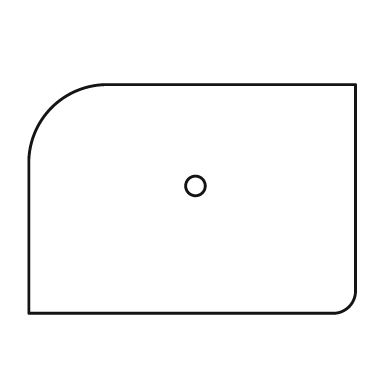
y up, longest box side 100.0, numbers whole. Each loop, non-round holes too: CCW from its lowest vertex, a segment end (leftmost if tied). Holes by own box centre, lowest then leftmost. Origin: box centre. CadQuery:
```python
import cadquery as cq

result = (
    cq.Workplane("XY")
    .moveTo(-50.0, -35.0)
    .lineTo(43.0, -35.0)
    .threePointArc((48.0, -33.0), (50.0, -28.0))
    .lineTo(50.0, 35.0)
    .lineTo(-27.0, 35.0)
    .threePointArc((-43.0, 28.0), (-50.0, 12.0))
    .close()
    .moveTo(1.0, 4.0)
    .circle(3.0)
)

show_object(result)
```